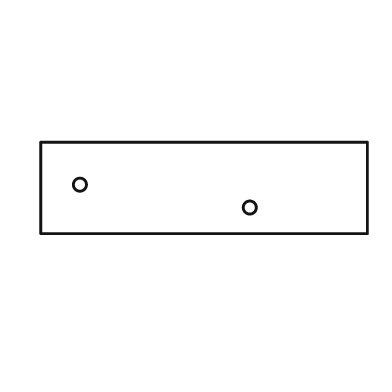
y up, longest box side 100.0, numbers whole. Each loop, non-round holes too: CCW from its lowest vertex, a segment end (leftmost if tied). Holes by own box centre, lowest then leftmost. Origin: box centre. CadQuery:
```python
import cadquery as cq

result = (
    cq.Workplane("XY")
    .moveTo(-50.0, -14.0)
    .lineTo(50.0, -14.0)
    .lineTo(50.0, 14.0)
    .lineTo(-50.0, 14.0)
    .close()
    .moveTo(14.0, -6.0)
    .circle(2.0)
    .moveTo(-38.0, 1.0)
    .circle(2.0)
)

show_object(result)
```